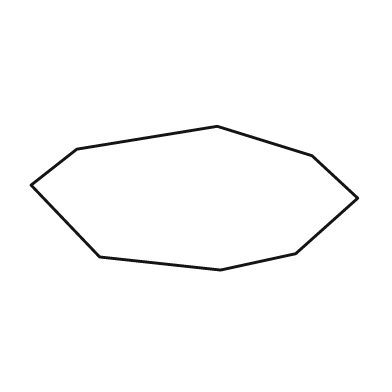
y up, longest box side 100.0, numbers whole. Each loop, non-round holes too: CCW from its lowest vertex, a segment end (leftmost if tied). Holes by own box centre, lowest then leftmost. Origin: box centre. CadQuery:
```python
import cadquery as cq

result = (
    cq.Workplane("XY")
    .moveTo(8.0, -22.0)
    .lineTo(31.0, -17.0)
    .lineTo(50.0, 0.0)
    .lineTo(36.0, 13.0)
    .lineTo(7.0, 22.0)
    .lineTo(-36.0, 15.0)
    .lineTo(-50.0, 4.0)
    .lineTo(-29.0, -18.0)
    .close()
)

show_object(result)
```